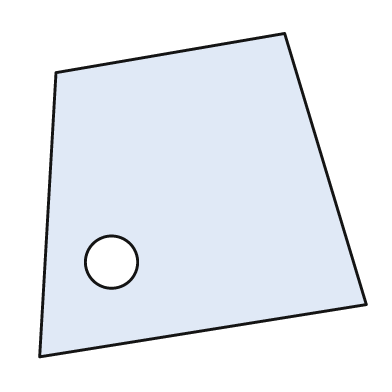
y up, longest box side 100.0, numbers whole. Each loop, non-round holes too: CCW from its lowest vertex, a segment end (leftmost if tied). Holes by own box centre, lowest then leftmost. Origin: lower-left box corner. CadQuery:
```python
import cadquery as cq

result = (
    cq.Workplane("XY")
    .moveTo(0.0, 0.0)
    .lineTo(100.0, 16.0)
    .lineTo(75.0, 99.0)
    .lineTo(5.0, 87.0)
    .close()
    .moveTo(22.0, 29.0)
    .circle(8.0)
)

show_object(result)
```